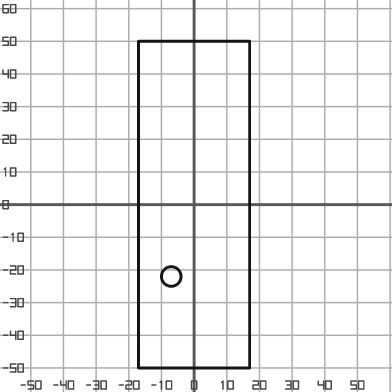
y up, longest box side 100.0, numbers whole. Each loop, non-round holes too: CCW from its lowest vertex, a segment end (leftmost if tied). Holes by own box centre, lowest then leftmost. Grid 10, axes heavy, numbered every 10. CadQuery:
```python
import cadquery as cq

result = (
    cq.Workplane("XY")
    .moveTo(-17.0, -50.0)
    .lineTo(17.0, -50.0)
    .lineTo(17.0, 50.0)
    .lineTo(-17.0, 50.0)
    .close()
    .moveTo(-7.0, -22.0)
    .circle(3.0)
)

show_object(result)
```